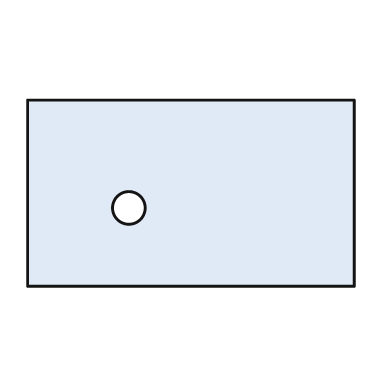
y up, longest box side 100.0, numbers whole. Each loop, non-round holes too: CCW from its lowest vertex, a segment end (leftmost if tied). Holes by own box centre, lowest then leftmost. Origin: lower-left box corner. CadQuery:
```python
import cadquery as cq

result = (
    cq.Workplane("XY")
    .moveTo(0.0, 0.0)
    .lineTo(100.0, 0.0)
    .lineTo(100.0, 57.0)
    .lineTo(0.0, 57.0)
    .close()
    .moveTo(31.0, 24.0)
    .circle(5.0)
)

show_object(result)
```